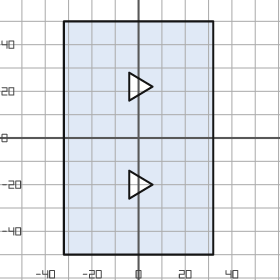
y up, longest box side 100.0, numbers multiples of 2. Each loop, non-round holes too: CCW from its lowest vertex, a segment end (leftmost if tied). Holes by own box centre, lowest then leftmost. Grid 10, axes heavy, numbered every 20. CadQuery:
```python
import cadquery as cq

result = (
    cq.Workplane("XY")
    .moveTo(-32.0, -50.0)
    .lineTo(32.0, -50.0)
    .lineTo(32.0, 50.0)
    .lineTo(-32.0, 50.0)
    .close()
    .moveTo(-4.0, -26.0)
    .lineTo(6.0, -20.0)
    .lineTo(-4.0, -14.0)
    .close()
    .moveTo(-4.0, 16.0)
    .lineTo(6.0, 22.0)
    .lineTo(-4.0, 28.0)
    .close()
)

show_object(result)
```